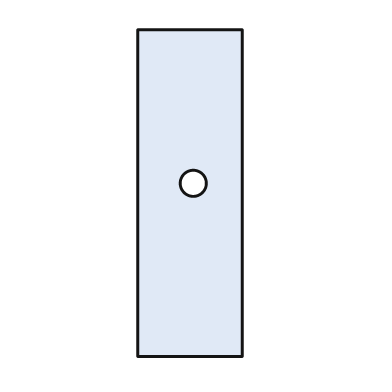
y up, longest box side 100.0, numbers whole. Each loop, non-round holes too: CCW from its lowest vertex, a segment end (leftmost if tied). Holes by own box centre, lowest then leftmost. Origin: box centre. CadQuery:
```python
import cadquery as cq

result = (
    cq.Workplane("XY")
    .moveTo(-16.0, -50.0)
    .lineTo(16.0, -50.0)
    .lineTo(16.0, 50.0)
    .lineTo(-16.0, 50.0)
    .close()
    .moveTo(1.0, 3.0)
    .circle(4.0)
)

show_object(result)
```